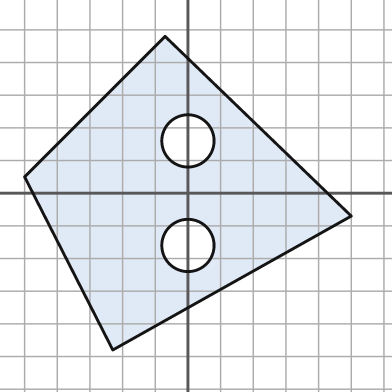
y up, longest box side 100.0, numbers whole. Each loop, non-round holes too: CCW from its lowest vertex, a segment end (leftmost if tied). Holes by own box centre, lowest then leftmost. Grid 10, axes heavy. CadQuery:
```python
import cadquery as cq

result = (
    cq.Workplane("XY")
    .moveTo(-23.0, -48.0)
    .lineTo(50.0, -7.0)
    .lineTo(-7.0, 48.0)
    .lineTo(-50.0, 5.0)
    .close()
    .moveTo(0.0, -16.0)
    .circle(8.0)
    .moveTo(0.0, 16.0)
    .circle(8.0)
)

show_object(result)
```